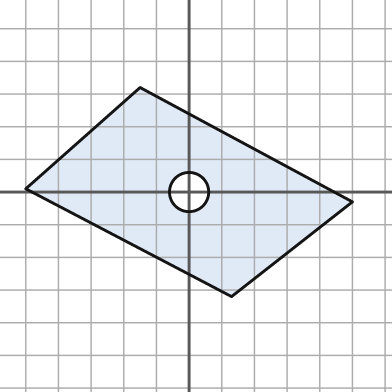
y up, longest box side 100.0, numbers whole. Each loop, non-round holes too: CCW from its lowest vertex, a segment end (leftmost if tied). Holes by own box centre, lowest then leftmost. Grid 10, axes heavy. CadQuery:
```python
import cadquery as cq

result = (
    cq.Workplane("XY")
    .moveTo(13.0, -32.0)
    .lineTo(50.0, -3.0)
    .lineTo(-15.0, 32.0)
    .lineTo(-50.0, 1.0)
    .close()
    .moveTo(0.0, 0.0)
    .circle(6.0)
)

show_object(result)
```